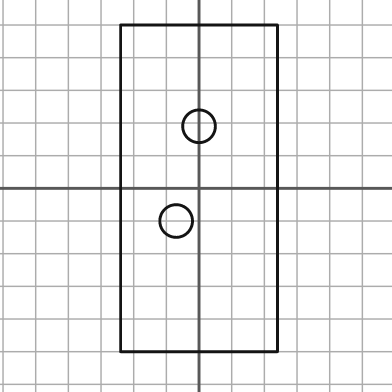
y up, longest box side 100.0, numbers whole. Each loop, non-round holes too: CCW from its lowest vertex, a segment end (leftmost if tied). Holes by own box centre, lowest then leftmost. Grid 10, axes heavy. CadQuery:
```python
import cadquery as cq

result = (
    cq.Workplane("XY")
    .moveTo(-24.0, -50.0)
    .lineTo(24.0, -50.0)
    .lineTo(24.0, 50.0)
    .lineTo(-24.0, 50.0)
    .close()
    .moveTo(-7.0, -10.0)
    .circle(5.0)
    .moveTo(0.0, 19.0)
    .circle(5.0)
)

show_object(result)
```